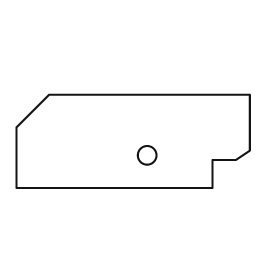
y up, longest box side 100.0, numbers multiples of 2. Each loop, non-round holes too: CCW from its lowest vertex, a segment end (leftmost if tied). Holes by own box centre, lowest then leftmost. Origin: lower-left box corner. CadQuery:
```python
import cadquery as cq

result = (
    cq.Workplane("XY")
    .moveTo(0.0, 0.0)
    .lineTo(84.0, 0.0)
    .lineTo(84.0, 12.0)
    .lineTo(94.0, 12.0)
    .lineTo(100.0, 16.0)
    .lineTo(100.0, 40.0)
    .lineTo(14.0, 40.0)
    .lineTo(0.0, 26.0)
    .close()
    .moveTo(56.0, 14.0)
    .circle(4.0)
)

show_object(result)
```